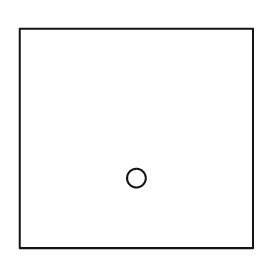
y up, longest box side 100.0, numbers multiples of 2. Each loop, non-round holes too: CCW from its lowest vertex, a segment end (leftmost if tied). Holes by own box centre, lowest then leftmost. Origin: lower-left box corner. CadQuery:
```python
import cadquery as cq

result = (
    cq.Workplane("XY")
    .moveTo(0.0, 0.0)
    .lineTo(100.0, 0.0)
    .lineTo(100.0, 94.0)
    .lineTo(0.0, 94.0)
    .close()
    .moveTo(50.0, 30.0)
    .circle(4.0)
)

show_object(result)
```